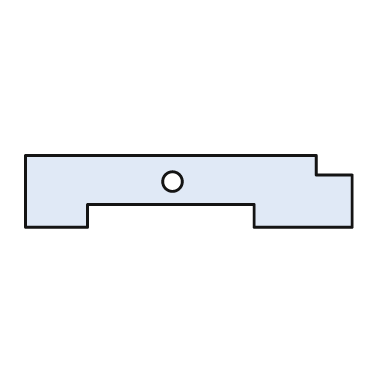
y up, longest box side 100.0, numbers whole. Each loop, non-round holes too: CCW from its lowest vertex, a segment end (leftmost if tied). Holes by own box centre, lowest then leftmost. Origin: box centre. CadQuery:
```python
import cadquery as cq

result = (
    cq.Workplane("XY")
    .moveTo(-50.0, -11.0)
    .lineTo(-31.0, -11.0)
    .lineTo(-31.0, -4.0)
    .lineTo(20.0, -4.0)
    .lineTo(20.0, -11.0)
    .lineTo(50.0, -11.0)
    .lineTo(50.0, 5.0)
    .lineTo(39.0, 5.0)
    .lineTo(39.0, 11.0)
    .lineTo(-50.0, 11.0)
    .close()
    .moveTo(-5.0, 3.0)
    .circle(3.0)
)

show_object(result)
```